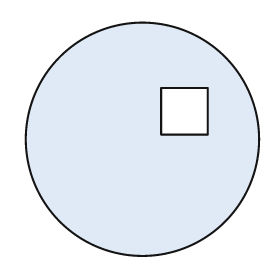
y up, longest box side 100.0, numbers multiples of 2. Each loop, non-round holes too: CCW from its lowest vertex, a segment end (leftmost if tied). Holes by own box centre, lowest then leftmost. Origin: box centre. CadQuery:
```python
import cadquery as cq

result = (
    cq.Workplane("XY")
    .moveTo(0.0, 0.0)
    .circle(50.0)
    .moveTo(8.0, 2.0)
    .lineTo(28.0, 2.0)
    .lineTo(28.0, 22.0)
    .lineTo(8.0, 22.0)
    .close()
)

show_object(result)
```